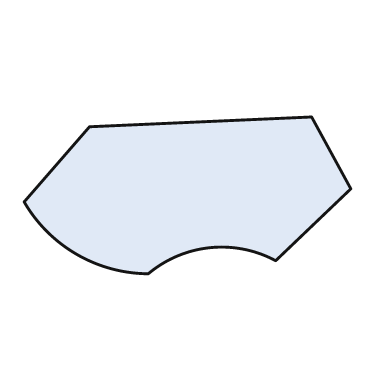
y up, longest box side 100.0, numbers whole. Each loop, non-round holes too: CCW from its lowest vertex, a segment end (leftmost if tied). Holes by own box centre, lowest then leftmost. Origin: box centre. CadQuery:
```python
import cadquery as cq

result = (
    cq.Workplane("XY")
    .moveTo(-12.0, -24.0)
    .threePointArc((7.0, -16.0), (27.0, -20.0))
    .lineTo(50.0, 2.0)
    .lineTo(38.0, 24.0)
    .lineTo(-30.0, 21.0)
    .lineTo(-50.0, -2.0)
    .threePointArc((-34.0, -18.0), (-12.0, -24.0))
    .close()
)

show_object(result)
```